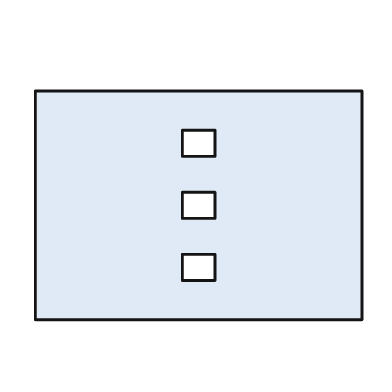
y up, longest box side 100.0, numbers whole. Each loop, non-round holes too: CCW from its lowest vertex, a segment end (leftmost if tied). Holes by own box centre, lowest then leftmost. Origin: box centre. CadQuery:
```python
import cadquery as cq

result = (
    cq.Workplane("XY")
    .moveTo(-50.0, -35.0)
    .lineTo(50.0, -35.0)
    .lineTo(50.0, 35.0)
    .lineTo(-50.0, 35.0)
    .close()
    .moveTo(-5.0, -23.0)
    .lineTo(5.0, -23.0)
    .lineTo(5.0, -15.0)
    .lineTo(-5.0, -15.0)
    .close()
    .moveTo(-5.0, -4.0)
    .lineTo(5.0, -4.0)
    .lineTo(5.0, 4.0)
    .lineTo(-5.0, 4.0)
    .close()
    .moveTo(-5.0, 15.0)
    .lineTo(5.0, 15.0)
    .lineTo(5.0, 23.0)
    .lineTo(-5.0, 23.0)
    .close()
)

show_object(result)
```